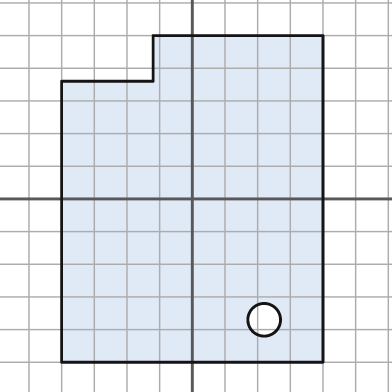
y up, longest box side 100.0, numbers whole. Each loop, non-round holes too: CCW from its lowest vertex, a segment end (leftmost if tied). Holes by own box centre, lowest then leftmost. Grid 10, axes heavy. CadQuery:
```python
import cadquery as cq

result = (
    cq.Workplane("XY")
    .moveTo(-40.0, -50.0)
    .lineTo(40.0, -50.0)
    .lineTo(40.0, 50.0)
    .lineTo(-12.0, 50.0)
    .lineTo(-12.0, 36.0)
    .lineTo(-40.0, 36.0)
    .close()
    .moveTo(22.0, -37.0)
    .circle(5.0)
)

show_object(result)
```